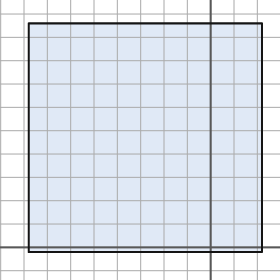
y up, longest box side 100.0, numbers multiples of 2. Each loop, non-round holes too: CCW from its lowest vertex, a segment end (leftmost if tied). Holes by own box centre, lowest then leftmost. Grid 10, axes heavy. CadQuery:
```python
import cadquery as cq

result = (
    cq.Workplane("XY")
    .moveTo(-78.0, -2.0)
    .lineTo(22.0, -2.0)
    .lineTo(22.0, 96.0)
    .lineTo(-78.0, 96.0)
    .close()
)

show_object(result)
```